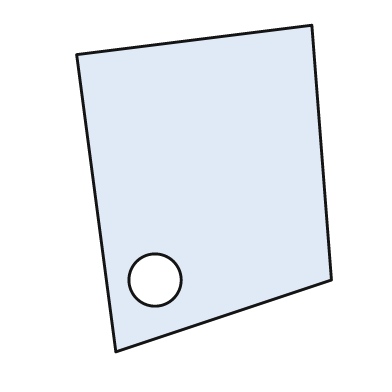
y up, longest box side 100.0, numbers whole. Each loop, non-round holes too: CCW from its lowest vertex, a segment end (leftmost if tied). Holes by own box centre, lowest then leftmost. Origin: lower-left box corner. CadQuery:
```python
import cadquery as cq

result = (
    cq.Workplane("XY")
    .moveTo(12.0, 0.0)
    .lineTo(78.0, 22.0)
    .lineTo(72.0, 100.0)
    .lineTo(0.0, 91.0)
    .close()
    .moveTo(24.0, 22.0)
    .circle(8.0)
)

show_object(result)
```